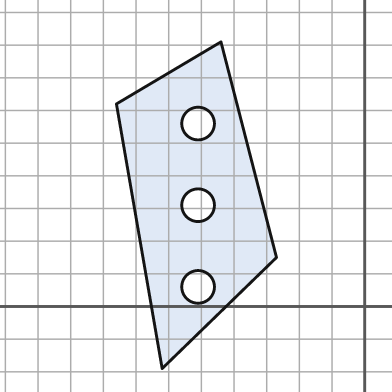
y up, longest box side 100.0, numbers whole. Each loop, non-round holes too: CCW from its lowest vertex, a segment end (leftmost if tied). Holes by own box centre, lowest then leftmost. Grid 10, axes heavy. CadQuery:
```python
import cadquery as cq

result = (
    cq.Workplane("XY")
    .moveTo(-62.0, -19.0)
    .lineTo(-27.0, 15.0)
    .lineTo(-44.0, 81.0)
    .lineTo(-76.0, 62.0)
    .close()
    .moveTo(-51.0, 6.0)
    .circle(5.0)
    .moveTo(-51.0, 31.0)
    .circle(5.0)
    .moveTo(-51.0, 56.0)
    .circle(5.0)
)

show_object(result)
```